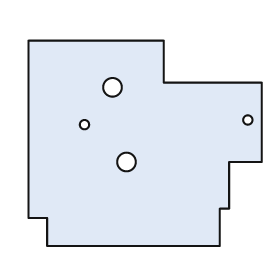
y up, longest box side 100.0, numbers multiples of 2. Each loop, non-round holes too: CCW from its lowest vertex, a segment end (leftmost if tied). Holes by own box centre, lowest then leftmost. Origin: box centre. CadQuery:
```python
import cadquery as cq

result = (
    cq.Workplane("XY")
    .moveTo(-42.0, -44.0)
    .lineTo(32.0, -44.0)
    .lineTo(32.0, -28.0)
    .lineTo(36.0, -28.0)
    .lineTo(36.0, -8.0)
    .lineTo(50.0, -8.0)
    .lineTo(50.0, 26.0)
    .lineTo(8.0, 26.0)
    .lineTo(8.0, 44.0)
    .lineTo(-50.0, 44.0)
    .lineTo(-50.0, -32.0)
    .lineTo(-42.0, -32.0)
    .close()
    .moveTo(-8.0, -8.0)
    .circle(4.0)
    .moveTo(-26.0, 8.0)
    .circle(2.0)
    .moveTo(44.0, 10.0)
    .circle(2.0)
    .moveTo(-14.0, 24.0)
    .circle(4.0)
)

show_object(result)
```